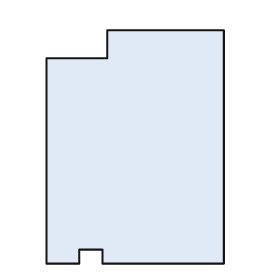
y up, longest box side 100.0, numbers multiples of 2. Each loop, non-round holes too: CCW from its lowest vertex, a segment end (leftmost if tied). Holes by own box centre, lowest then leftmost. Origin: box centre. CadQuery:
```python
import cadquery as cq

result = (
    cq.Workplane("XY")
    .moveTo(-38.0, -50.0)
    .lineTo(-24.0, -50.0)
    .lineTo(-24.0, -44.0)
    .lineTo(-14.0, -44.0)
    .lineTo(-14.0, -50.0)
    .lineTo(38.0, -50.0)
    .lineTo(38.0, 50.0)
    .lineTo(-12.0, 50.0)
    .lineTo(-12.0, 38.0)
    .lineTo(-38.0, 38.0)
    .close()
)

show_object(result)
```